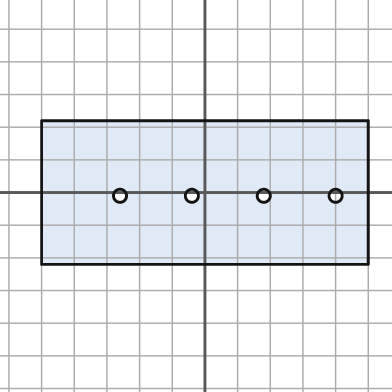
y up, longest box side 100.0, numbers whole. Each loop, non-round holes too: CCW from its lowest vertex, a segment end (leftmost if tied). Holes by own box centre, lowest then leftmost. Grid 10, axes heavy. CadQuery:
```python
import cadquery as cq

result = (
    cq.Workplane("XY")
    .moveTo(-50.0, -22.0)
    .lineTo(50.0, -22.0)
    .lineTo(50.0, 22.0)
    .lineTo(-50.0, 22.0)
    .close()
    .moveTo(-26.0, -1.0)
    .circle(2.0)
    .moveTo(-4.0, -1.0)
    .circle(2.0)
    .moveTo(18.0, -1.0)
    .circle(2.0)
    .moveTo(40.0, -1.0)
    .circle(2.0)
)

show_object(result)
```